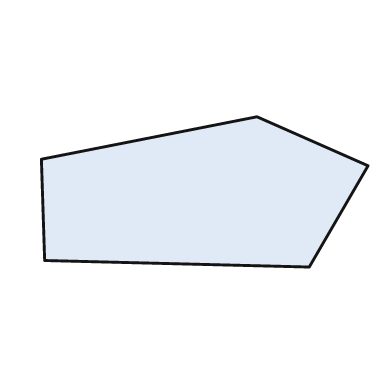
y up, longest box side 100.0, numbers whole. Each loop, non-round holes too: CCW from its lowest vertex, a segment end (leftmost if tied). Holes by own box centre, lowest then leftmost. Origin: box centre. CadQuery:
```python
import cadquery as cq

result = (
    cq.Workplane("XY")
    .moveTo(32.0, -23.0)
    .lineTo(50.0, 8.0)
    .lineTo(16.0, 23.0)
    .lineTo(-50.0, 10.0)
    .lineTo(-49.0, -21.0)
    .close()
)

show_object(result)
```